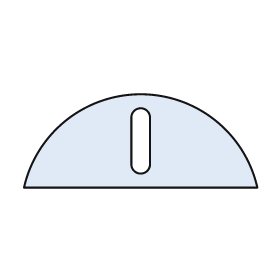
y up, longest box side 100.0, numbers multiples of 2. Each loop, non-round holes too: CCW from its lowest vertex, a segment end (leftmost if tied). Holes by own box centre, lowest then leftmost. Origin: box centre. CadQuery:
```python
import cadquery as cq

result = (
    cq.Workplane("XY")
    .moveTo(-50.0, -20.0)
    .lineTo(50.0, -20.0)
    .threePointArc((0.0, 20.0), (-50.0, -20.0))
    .close()
    .moveTo(-4.0, -10.0)
    .threePointArc((0.0, -14.0), (4.0, -10.0))
    .lineTo(4.0, 10.0)
    .threePointArc((0.0, 14.0), (-4.0, 10.0))
    .close()
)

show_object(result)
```